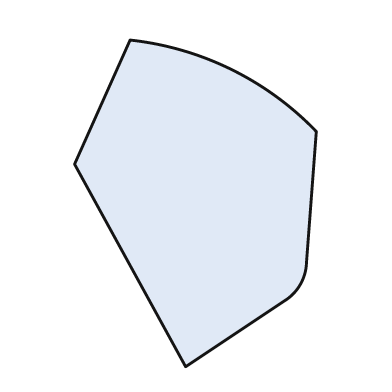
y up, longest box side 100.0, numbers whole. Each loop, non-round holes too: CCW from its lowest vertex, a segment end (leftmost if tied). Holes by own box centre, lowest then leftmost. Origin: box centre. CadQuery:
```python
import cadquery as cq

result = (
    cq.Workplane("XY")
    .moveTo(-3.0, -50.0)
    .lineTo(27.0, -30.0)
    .threePointArc((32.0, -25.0), (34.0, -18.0))
    .lineTo(37.0, 22.0)
    .threePointArc((11.0, 41.0), (-20.0, 50.0))
    .lineTo(-37.0, 12.0)
    .close()
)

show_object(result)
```